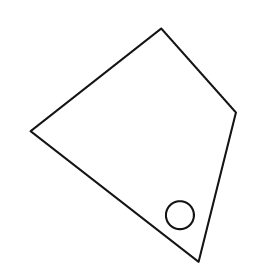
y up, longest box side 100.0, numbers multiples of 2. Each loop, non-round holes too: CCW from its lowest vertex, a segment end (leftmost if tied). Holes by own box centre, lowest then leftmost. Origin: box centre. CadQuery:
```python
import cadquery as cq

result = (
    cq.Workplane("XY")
    .moveTo(28.0, -50.0)
    .lineTo(44.0, 14.0)
    .lineTo(12.0, 50.0)
    .lineTo(-44.0, 6.0)
    .close()
    .moveTo(20.0, -30.0)
    .circle(6.0)
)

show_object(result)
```